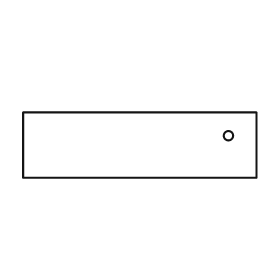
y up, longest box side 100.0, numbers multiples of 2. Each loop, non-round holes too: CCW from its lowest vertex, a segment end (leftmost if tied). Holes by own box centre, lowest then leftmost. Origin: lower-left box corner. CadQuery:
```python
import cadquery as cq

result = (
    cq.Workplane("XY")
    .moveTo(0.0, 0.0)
    .lineTo(100.0, 0.0)
    .lineTo(100.0, 28.0)
    .lineTo(0.0, 28.0)
    .close()
    .moveTo(88.0, 18.0)
    .circle(2.0)
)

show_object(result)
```